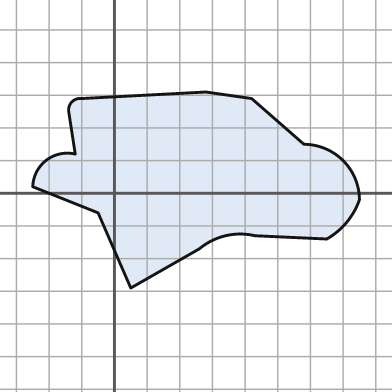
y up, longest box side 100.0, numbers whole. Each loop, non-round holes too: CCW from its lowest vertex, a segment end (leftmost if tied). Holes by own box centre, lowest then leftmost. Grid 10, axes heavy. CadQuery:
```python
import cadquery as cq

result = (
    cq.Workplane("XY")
    .moveTo(5.0, -29.0)
    .lineTo(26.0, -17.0)
    .threePointArc((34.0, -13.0), (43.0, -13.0))
    .lineTo(65.0, -14.0)
    .threePointArc((71.0, -9.0), (75.0, -2.0))
    .threePointArc((70.0, 10.0), (58.0, 15.0))
    .lineTo(42.0, 29.0)
    .lineTo(28.0, 31.0)
    .lineTo(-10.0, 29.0)
    .threePointArc((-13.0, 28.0), (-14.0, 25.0))
    .lineTo(-12.0, 12.0)
    .threePointArc((-21.0, 10.0), (-25.0, 2.0))
    .lineTo(-5.0, -6.0)
    .close()
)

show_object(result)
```